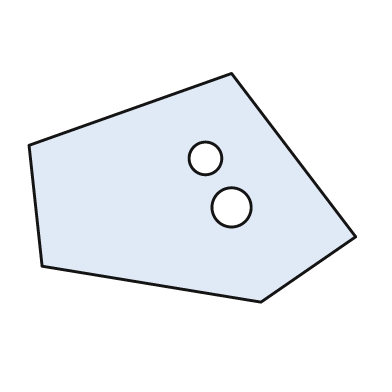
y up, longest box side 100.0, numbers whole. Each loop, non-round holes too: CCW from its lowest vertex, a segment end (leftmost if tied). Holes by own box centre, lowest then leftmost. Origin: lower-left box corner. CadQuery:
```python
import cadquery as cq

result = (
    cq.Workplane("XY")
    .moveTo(71.0, 0.0)
    .lineTo(100.0, 20.0)
    .lineTo(62.0, 70.0)
    .lineTo(0.0, 48.0)
    .lineTo(4.0, 11.0)
    .close()
    .moveTo(62.0, 29.0)
    .circle(6.0)
    .moveTo(54.0, 44.0)
    .circle(5.0)
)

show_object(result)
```